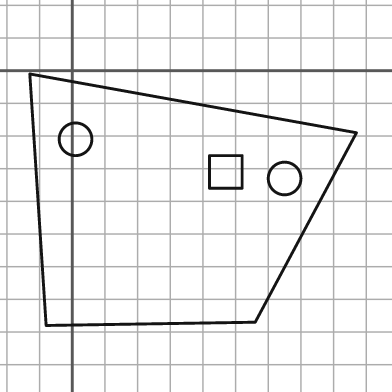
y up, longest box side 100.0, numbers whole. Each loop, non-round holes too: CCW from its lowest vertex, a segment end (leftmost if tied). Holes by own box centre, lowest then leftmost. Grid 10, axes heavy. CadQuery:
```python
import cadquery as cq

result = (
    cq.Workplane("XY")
    .moveTo(-8.0, -78.0)
    .lineTo(56.0, -77.0)
    .lineTo(87.0, -19.0)
    .lineTo(-13.0, -1.0)
    .close()
    .moveTo(65.0, -33.0)
    .circle(5.0)
    .moveTo(42.0, -36.0)
    .lineTo(52.0, -36.0)
    .lineTo(52.0, -26.0)
    .lineTo(42.0, -26.0)
    .close()
    .moveTo(1.0, -21.0)
    .circle(5.0)
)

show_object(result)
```